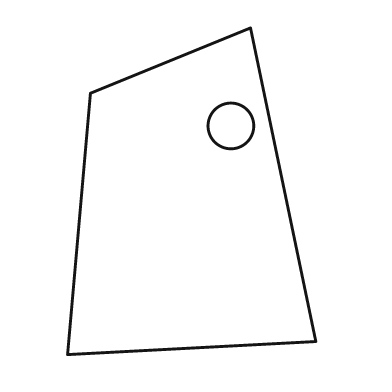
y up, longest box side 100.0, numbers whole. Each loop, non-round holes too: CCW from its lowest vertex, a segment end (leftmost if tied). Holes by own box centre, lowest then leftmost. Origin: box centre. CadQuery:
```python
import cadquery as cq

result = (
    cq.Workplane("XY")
    .moveTo(-38.0, -50.0)
    .lineTo(38.0, -46.0)
    .lineTo(18.0, 50.0)
    .lineTo(-31.0, 30.0)
    .close()
    .moveTo(12.0, 20.0)
    .circle(7.0)
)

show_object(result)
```